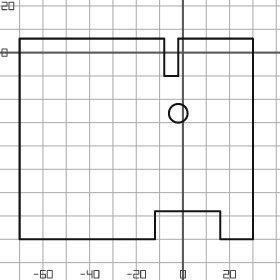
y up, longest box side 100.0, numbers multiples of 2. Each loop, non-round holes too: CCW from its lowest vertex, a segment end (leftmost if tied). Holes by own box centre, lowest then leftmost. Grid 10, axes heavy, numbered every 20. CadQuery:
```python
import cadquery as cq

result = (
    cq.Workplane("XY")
    .moveTo(-70.0, -80.0)
    .lineTo(-12.0, -80.0)
    .lineTo(-12.0, -68.0)
    .lineTo(16.0, -68.0)
    .lineTo(16.0, -80.0)
    .lineTo(30.0, -80.0)
    .lineTo(30.0, 6.0)
    .lineTo(-2.0, 6.0)
    .lineTo(-2.0, -10.0)
    .lineTo(-8.0, -10.0)
    .lineTo(-8.0, 6.0)
    .lineTo(-70.0, 6.0)
    .close()
    .moveTo(-2.0, -26.0)
    .circle(4.0)
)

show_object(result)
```